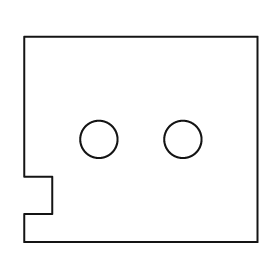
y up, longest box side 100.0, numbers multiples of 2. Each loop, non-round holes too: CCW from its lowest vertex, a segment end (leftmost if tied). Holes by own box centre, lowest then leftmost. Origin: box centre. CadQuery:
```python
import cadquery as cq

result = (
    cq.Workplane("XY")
    .moveTo(-50.0, -44.0)
    .lineTo(50.0, -44.0)
    .lineTo(50.0, 44.0)
    .lineTo(-50.0, 44.0)
    .lineTo(-50.0, -16.0)
    .lineTo(-38.0, -16.0)
    .lineTo(-38.0, -32.0)
    .lineTo(-50.0, -32.0)
    .close()
    .moveTo(-18.0, 0.0)
    .circle(8.0)
    .moveTo(18.0, 0.0)
    .circle(8.0)
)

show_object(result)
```